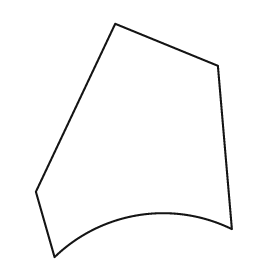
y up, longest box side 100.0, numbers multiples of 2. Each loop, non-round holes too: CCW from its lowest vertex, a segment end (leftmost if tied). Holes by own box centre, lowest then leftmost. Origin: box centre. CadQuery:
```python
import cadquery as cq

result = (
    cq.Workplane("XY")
    .moveTo(-34.0, -50.0)
    .threePointArc((2.0, -32.0), (42.0, -38.0))
    .lineTo(36.0, 32.0)
    .lineTo(-8.0, 50.0)
    .lineTo(-42.0, -22.0)
    .close()
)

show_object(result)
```